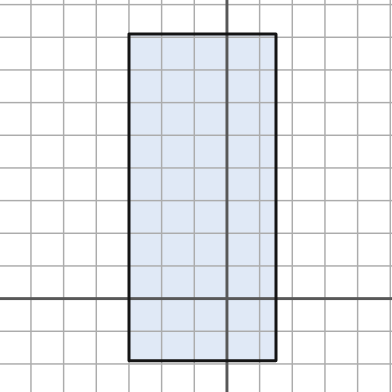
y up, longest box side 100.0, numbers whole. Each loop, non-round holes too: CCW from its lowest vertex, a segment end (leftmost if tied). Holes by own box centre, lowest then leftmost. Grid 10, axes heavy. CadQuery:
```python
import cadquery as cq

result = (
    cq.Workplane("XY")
    .moveTo(-30.0, -19.0)
    .lineTo(15.0, -19.0)
    .lineTo(15.0, 81.0)
    .lineTo(-30.0, 81.0)
    .close()
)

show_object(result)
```